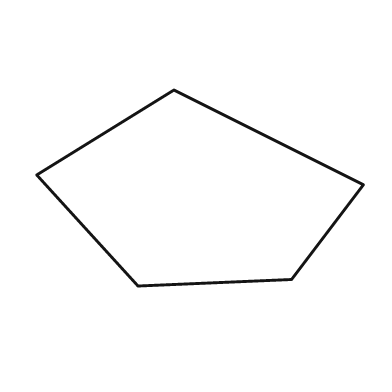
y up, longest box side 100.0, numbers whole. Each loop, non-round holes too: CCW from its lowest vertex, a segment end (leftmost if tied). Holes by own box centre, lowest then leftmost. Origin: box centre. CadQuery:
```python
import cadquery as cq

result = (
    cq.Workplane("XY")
    .moveTo(-19.0, -30.0)
    .lineTo(28.0, -28.0)
    .lineTo(50.0, 1.0)
    .lineTo(-8.0, 30.0)
    .lineTo(-50.0, 4.0)
    .close()
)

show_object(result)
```